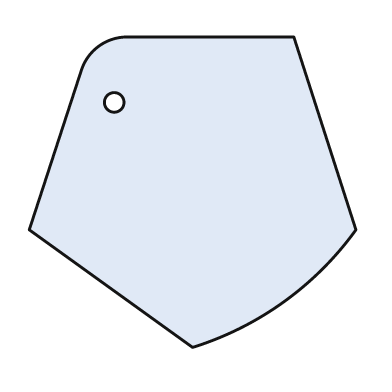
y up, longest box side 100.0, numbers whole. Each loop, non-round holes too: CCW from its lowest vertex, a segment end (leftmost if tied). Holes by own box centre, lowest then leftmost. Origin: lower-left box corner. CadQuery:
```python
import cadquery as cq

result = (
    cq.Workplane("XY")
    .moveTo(50.0, 0.0)
    .threePointArc((78.0, 14.0), (100.0, 36.0))
    .lineTo(81.0, 95.0)
    .lineTo(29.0, 95.0)
    .threePointArc((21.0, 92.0), (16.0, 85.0))
    .lineTo(0.0, 36.0)
    .close()
    .moveTo(26.0, 75.0)
    .circle(3.0)
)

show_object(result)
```